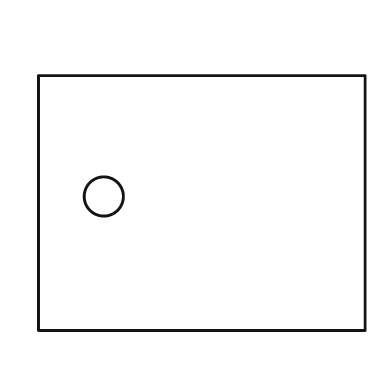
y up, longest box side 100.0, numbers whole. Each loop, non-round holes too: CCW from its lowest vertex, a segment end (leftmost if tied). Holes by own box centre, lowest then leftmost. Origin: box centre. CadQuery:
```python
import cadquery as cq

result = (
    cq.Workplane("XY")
    .moveTo(-50.0, -39.0)
    .lineTo(50.0, -39.0)
    .lineTo(50.0, 39.0)
    .lineTo(-50.0, 39.0)
    .close()
    .moveTo(-30.0, 2.0)
    .circle(6.0)
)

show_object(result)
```